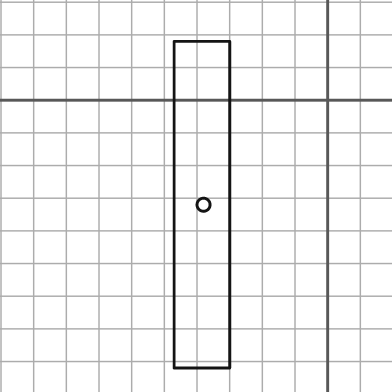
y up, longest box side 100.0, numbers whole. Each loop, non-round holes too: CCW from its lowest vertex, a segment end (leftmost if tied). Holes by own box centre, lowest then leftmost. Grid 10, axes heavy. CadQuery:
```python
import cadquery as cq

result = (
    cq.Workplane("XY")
    .moveTo(-47.0, -82.0)
    .lineTo(-30.0, -82.0)
    .lineTo(-30.0, 18.0)
    .lineTo(-47.0, 18.0)
    .close()
    .moveTo(-38.0, -32.0)
    .circle(2.0)
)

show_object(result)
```